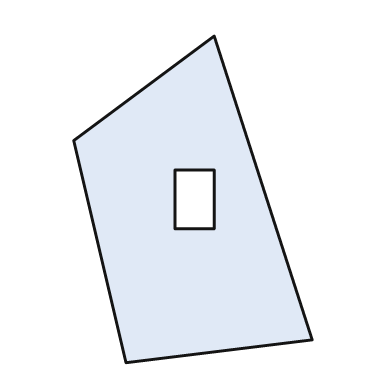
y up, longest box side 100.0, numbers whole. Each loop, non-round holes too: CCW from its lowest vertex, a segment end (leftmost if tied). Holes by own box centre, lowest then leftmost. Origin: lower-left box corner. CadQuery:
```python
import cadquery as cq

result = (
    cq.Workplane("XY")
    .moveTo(16.0, 0.0)
    .lineTo(73.0, 7.0)
    .lineTo(43.0, 100.0)
    .lineTo(0.0, 68.0)
    .close()
    .moveTo(31.0, 41.0)
    .lineTo(43.0, 41.0)
    .lineTo(43.0, 59.0)
    .lineTo(31.0, 59.0)
    .close()
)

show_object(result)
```